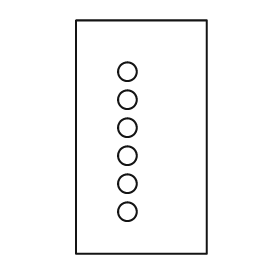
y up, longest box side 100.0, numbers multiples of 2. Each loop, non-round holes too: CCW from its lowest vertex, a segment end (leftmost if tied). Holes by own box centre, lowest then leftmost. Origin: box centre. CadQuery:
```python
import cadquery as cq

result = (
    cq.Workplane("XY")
    .moveTo(-28.0, -50.0)
    .lineTo(28.0, -50.0)
    .lineTo(28.0, 50.0)
    .lineTo(-28.0, 50.0)
    .close()
    .moveTo(-6.0, -32.0)
    .circle(4.0)
    .moveTo(-6.0, -20.0)
    .circle(4.0)
    .moveTo(-6.0, -8.0)
    .circle(4.0)
    .moveTo(-6.0, 4.0)
    .circle(4.0)
    .moveTo(-6.0, 16.0)
    .circle(4.0)
    .moveTo(-6.0, 28.0)
    .circle(4.0)
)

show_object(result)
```